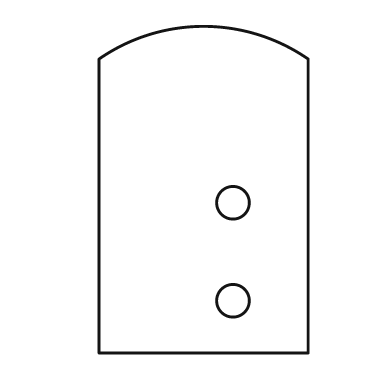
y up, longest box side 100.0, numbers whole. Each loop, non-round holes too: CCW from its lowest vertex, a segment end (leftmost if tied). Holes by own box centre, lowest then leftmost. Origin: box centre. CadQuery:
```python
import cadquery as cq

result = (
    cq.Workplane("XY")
    .moveTo(-32.0, -50.0)
    .lineTo(32.0, -50.0)
    .lineTo(32.0, 40.0)
    .threePointArc((0.0, 50.0), (-32.0, 40.0))
    .close()
    .moveTo(9.0, -34.0)
    .circle(5.0)
    .moveTo(9.0, -4.0)
    .circle(5.0)
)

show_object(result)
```